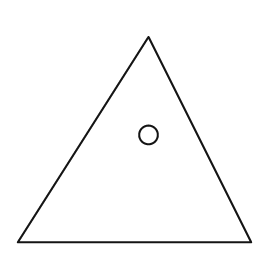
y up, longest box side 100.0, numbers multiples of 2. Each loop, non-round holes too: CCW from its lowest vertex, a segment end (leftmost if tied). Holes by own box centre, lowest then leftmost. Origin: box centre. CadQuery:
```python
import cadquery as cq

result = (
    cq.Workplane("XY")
    .moveTo(-50.0, -44.0)
    .lineTo(50.0, -44.0)
    .lineTo(6.0, 44.0)
    .close()
    .moveTo(6.0, 2.0)
    .circle(4.0)
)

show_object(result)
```